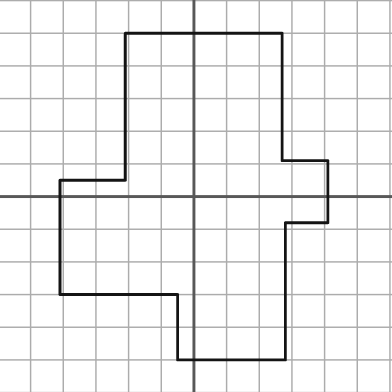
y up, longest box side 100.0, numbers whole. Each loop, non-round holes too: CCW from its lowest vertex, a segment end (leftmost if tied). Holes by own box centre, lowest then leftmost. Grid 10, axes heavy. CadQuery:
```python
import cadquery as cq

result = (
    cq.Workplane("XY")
    .moveTo(-5.0, -50.0)
    .lineTo(28.0, -50.0)
    .lineTo(28.0, -8.0)
    .lineTo(41.0, -8.0)
    .lineTo(41.0, 11.0)
    .lineTo(27.0, 11.0)
    .lineTo(27.0, 50.0)
    .lineTo(-21.0, 50.0)
    .lineTo(-21.0, 5.0)
    .lineTo(-41.0, 5.0)
    .lineTo(-41.0, -30.0)
    .lineTo(-5.0, -30.0)
    .close()
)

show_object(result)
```